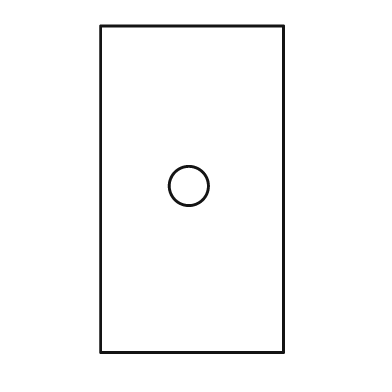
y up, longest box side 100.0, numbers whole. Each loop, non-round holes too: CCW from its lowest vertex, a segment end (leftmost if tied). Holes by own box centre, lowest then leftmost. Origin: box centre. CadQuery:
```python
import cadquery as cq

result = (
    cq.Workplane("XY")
    .moveTo(-28.0, -50.0)
    .lineTo(28.0, -50.0)
    .lineTo(28.0, 50.0)
    .lineTo(-28.0, 50.0)
    .close()
    .moveTo(-1.0, 1.0)
    .circle(6.0)
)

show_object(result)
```